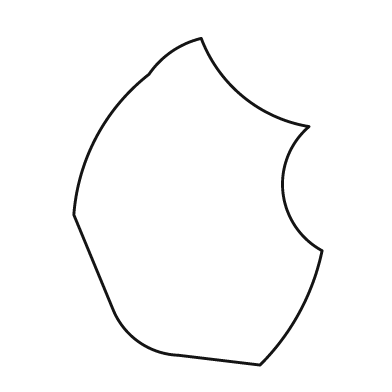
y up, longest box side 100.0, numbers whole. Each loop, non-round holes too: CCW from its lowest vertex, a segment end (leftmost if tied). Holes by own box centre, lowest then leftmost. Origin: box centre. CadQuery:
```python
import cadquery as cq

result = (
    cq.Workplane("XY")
    .moveTo(19.0, -50.0)
    .threePointArc((31.0, -34.0), (38.0, -15.0))
    .threePointArc((26.0, 3.0), (34.0, 23.0))
    .threePointArc((14.0, 32.0), (1.0, 50.0))
    .threePointArc((-8.0, 46.0), (-15.0, 39.0))
    .threePointArc((-31.0, 20.0), (-38.0, -4.0))
    .lineTo(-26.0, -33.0)
    .threePointArc((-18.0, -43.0), (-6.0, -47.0))
    .close()
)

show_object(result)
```